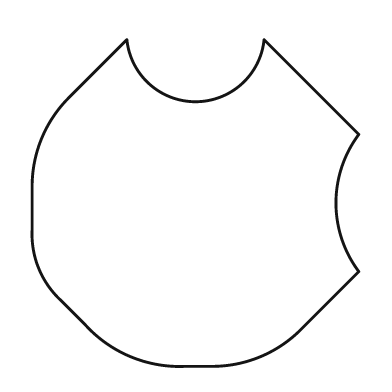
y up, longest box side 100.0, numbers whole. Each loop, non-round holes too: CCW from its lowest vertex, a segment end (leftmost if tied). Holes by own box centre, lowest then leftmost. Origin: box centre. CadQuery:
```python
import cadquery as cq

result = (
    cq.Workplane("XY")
    .moveTo(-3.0, -50.0)
    .lineTo(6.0, -50.0)
    .threePointArc((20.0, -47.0), (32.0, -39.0))
    .lineTo(50.0, -21.0)
    .threePointArc((43.0, 0.0), (50.0, 21.0))
    .lineTo(21.0, 50.0)
    .threePointArc((0.0, 31.0), (-21.0, 50.0))
    .lineTo(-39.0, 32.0)
    .threePointArc((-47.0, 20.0), (-50.0, 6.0))
    .lineTo(-50.0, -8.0)
    .threePointArc((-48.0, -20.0), (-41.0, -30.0))
    .lineTo(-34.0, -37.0)
    .threePointArc((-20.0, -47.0), (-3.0, -50.0))
    .close()
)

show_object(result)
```